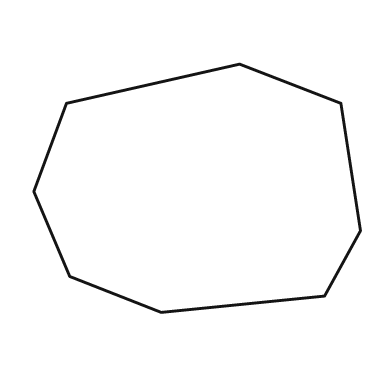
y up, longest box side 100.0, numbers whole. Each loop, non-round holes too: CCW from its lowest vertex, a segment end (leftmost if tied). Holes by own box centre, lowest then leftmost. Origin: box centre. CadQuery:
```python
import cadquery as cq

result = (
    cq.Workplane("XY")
    .moveTo(-11.0, -38.0)
    .lineTo(39.0, -33.0)
    .lineTo(50.0, -13.0)
    .lineTo(44.0, 26.0)
    .lineTo(13.0, 38.0)
    .lineTo(-40.0, 26.0)
    .lineTo(-50.0, -1.0)
    .lineTo(-39.0, -27.0)
    .close()
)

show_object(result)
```